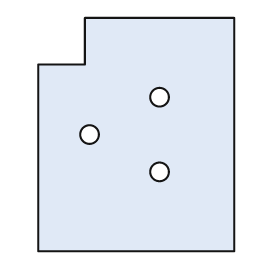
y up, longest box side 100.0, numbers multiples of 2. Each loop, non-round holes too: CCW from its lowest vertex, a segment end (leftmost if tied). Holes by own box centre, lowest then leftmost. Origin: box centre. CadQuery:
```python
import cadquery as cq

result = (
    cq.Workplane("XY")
    .moveTo(-42.0, -50.0)
    .lineTo(42.0, -50.0)
    .lineTo(42.0, 50.0)
    .lineTo(-22.0, 50.0)
    .lineTo(-22.0, 30.0)
    .lineTo(-42.0, 30.0)
    .close()
    .moveTo(10.0, -16.0)
    .circle(4.0)
    .moveTo(-20.0, 0.0)
    .circle(4.0)
    .moveTo(10.0, 16.0)
    .circle(4.0)
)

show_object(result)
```